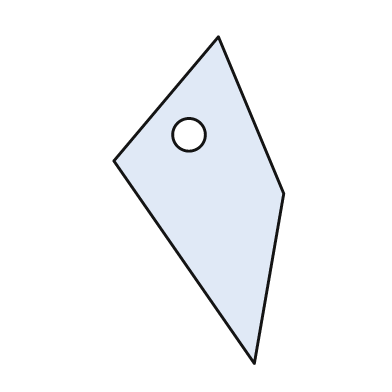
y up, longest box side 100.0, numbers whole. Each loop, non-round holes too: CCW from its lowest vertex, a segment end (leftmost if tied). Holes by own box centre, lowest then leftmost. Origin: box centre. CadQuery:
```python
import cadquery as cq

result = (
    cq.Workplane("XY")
    .moveTo(17.0, -50.0)
    .lineTo(26.0, 2.0)
    .lineTo(6.0, 50.0)
    .lineTo(-26.0, 12.0)
    .close()
    .moveTo(-3.0, 20.0)
    .circle(5.0)
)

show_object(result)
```